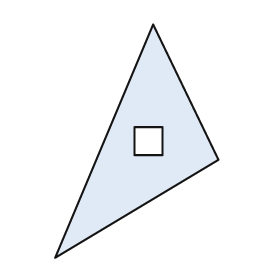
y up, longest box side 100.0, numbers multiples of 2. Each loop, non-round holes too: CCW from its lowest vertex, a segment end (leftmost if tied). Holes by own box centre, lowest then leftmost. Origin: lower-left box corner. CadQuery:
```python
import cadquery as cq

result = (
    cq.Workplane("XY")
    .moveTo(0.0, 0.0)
    .lineTo(70.0, 42.0)
    .lineTo(42.0, 100.0)
    .close()
    .moveTo(34.0, 44.0)
    .lineTo(46.0, 44.0)
    .lineTo(46.0, 56.0)
    .lineTo(34.0, 56.0)
    .close()
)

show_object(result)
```